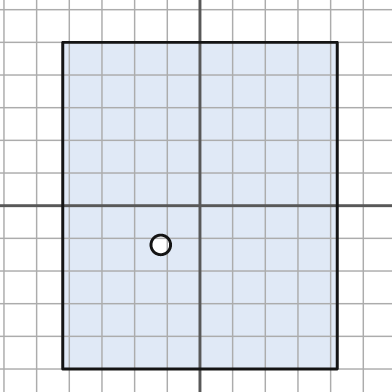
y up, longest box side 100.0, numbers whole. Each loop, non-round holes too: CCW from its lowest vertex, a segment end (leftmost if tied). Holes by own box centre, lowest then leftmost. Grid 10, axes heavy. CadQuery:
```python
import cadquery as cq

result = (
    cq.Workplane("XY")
    .moveTo(-42.0, -50.0)
    .lineTo(42.0, -50.0)
    .lineTo(42.0, 50.0)
    .lineTo(-42.0, 50.0)
    .close()
    .moveTo(-12.0, -12.0)
    .circle(3.0)
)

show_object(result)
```